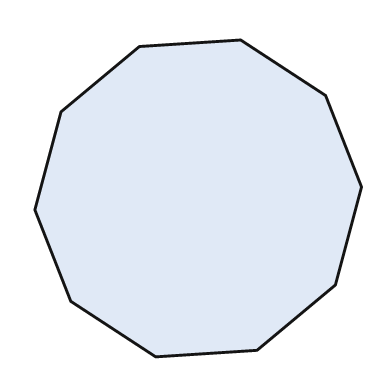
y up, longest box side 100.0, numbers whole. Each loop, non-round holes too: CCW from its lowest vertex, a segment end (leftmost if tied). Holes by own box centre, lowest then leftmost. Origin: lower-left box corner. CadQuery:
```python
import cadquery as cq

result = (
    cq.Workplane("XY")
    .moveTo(37.0, 0.0)
    .lineTo(68.0, 2.0)
    .lineTo(92.0, 22.0)
    .lineTo(100.0, 52.0)
    .lineTo(89.0, 80.0)
    .lineTo(63.0, 97.0)
    .lineTo(32.0, 95.0)
    .lineTo(8.0, 75.0)
    .lineTo(0.0, 45.0)
    .lineTo(11.0, 17.0)
    .close()
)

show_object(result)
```